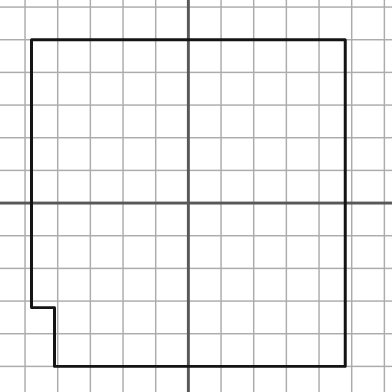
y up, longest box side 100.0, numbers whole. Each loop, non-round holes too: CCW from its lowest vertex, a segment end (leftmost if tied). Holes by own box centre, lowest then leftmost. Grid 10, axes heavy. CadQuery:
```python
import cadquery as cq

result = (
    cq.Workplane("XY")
    .moveTo(-41.0, -50.0)
    .lineTo(48.0, -50.0)
    .lineTo(48.0, 50.0)
    .lineTo(-48.0, 50.0)
    .lineTo(-48.0, -32.0)
    .lineTo(-41.0, -32.0)
    .close()
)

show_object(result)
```